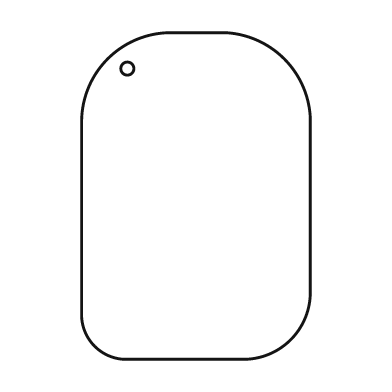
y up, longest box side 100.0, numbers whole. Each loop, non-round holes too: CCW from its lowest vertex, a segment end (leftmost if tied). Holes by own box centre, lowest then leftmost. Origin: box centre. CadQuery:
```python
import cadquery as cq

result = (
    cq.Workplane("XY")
    .moveTo(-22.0, -50.0)
    .lineTo(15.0, -50.0)
    .threePointArc((29.0, -44.0), (35.0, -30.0))
    .lineTo(35.0, 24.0)
    .threePointArc((27.0, 42.0), (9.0, 50.0))
    .lineTo(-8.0, 50.0)
    .threePointArc((-27.0, 42.0), (-35.0, 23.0))
    .lineTo(-35.0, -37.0)
    .threePointArc((-31.0, -46.0), (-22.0, -50.0))
    .close()
    .moveTo(-21.0, 39.0)
    .circle(2.0)
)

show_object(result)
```